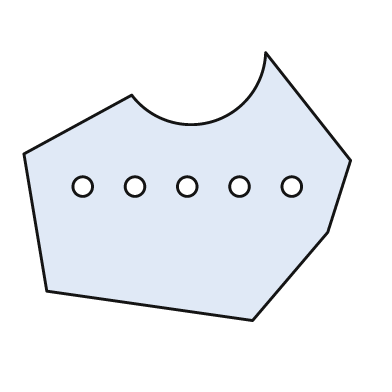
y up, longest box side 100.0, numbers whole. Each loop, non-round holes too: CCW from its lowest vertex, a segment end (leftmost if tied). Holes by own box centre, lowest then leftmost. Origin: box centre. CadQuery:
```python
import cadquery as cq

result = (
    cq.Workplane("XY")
    .moveTo(20.0, -41.0)
    .lineTo(43.0, -14.0)
    .lineTo(50.0, 8.0)
    .lineTo(24.0, 41.0)
    .threePointArc((8.0, 20.0), (-17.0, 28.0))
    .lineTo(-50.0, 10.0)
    .lineTo(-43.0, -32.0)
    .close()
    .moveTo(-32.0, 0.0)
    .circle(3.0)
    .moveTo(-16.0, 0.0)
    .circle(3.0)
    .moveTo(0.0, 0.0)
    .circle(3.0)
    .moveTo(16.0, 0.0)
    .circle(3.0)
    .moveTo(32.0, 0.0)
    .circle(3.0)
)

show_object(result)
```